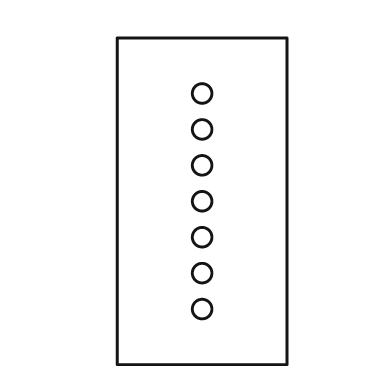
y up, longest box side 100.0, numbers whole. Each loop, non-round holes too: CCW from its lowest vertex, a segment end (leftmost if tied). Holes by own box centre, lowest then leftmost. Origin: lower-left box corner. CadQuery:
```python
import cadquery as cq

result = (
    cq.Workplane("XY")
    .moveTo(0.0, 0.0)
    .lineTo(52.0, 0.0)
    .lineTo(52.0, 100.0)
    .lineTo(0.0, 100.0)
    .close()
    .moveTo(26.0, 17.0)
    .circle(3.0)
    .moveTo(26.0, 28.0)
    .circle(3.0)
    .moveTo(26.0, 39.0)
    .circle(3.0)
    .moveTo(26.0, 50.0)
    .circle(3.0)
    .moveTo(26.0, 61.0)
    .circle(3.0)
    .moveTo(26.0, 72.0)
    .circle(3.0)
    .moveTo(26.0, 83.0)
    .circle(3.0)
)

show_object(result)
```